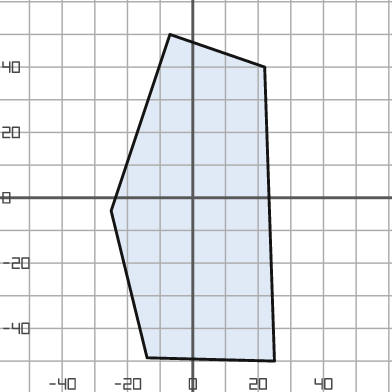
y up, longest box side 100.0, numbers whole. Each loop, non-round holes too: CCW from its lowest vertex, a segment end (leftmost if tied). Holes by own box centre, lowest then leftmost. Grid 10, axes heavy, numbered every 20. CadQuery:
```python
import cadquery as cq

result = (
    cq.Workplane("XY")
    .moveTo(25.0, -50.0)
    .lineTo(22.0, 40.0)
    .lineTo(-7.0, 50.0)
    .lineTo(-25.0, -4.0)
    .lineTo(-14.0, -49.0)
    .close()
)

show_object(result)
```